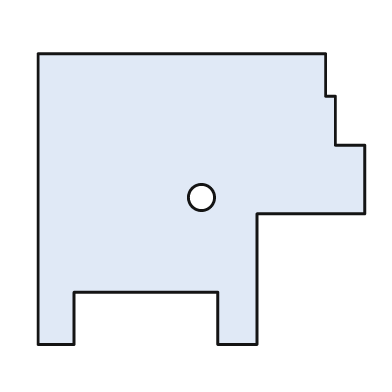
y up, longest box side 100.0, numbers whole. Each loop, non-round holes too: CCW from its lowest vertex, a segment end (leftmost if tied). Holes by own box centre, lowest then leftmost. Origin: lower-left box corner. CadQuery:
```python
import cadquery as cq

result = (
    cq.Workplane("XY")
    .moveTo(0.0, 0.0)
    .lineTo(11.0, 0.0)
    .lineTo(11.0, 16.0)
    .lineTo(55.0, 16.0)
    .lineTo(55.0, 0.0)
    .lineTo(67.0, 0.0)
    .lineTo(67.0, 40.0)
    .lineTo(100.0, 40.0)
    .lineTo(100.0, 61.0)
    .lineTo(91.0, 61.0)
    .lineTo(91.0, 76.0)
    .lineTo(88.0, 76.0)
    .lineTo(88.0, 89.0)
    .lineTo(0.0, 89.0)
    .close()
    .moveTo(50.0, 45.0)
    .circle(4.0)
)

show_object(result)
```